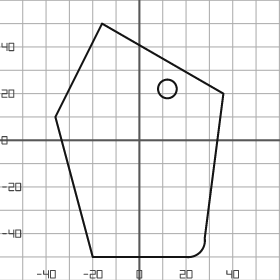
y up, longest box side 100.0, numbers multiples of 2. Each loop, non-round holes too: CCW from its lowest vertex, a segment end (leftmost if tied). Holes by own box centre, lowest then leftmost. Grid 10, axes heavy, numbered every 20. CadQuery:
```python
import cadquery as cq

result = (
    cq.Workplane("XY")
    .moveTo(-20.0, -50.0)
    .lineTo(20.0, -50.0)
    .threePointArc((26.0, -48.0), (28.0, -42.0))
    .lineTo(36.0, 20.0)
    .lineTo(-16.0, 50.0)
    .lineTo(-36.0, 10.0)
    .close()
    .moveTo(12.0, 22.0)
    .circle(4.0)
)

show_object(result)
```